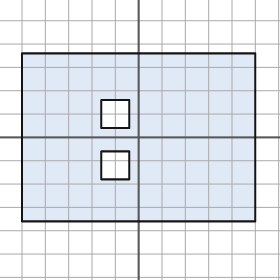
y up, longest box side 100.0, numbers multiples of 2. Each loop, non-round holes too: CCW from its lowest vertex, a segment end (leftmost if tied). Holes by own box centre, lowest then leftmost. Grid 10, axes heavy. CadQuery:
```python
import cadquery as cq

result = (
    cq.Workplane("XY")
    .moveTo(-50.0, -36.0)
    .lineTo(50.0, -36.0)
    .lineTo(50.0, 36.0)
    .lineTo(-50.0, 36.0)
    .close()
    .moveTo(-16.0, -18.0)
    .lineTo(-4.0, -18.0)
    .lineTo(-4.0, -6.0)
    .lineTo(-16.0, -6.0)
    .close()
    .moveTo(-16.0, 4.0)
    .lineTo(-4.0, 4.0)
    .lineTo(-4.0, 16.0)
    .lineTo(-16.0, 16.0)
    .close()
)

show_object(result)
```